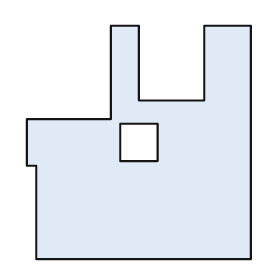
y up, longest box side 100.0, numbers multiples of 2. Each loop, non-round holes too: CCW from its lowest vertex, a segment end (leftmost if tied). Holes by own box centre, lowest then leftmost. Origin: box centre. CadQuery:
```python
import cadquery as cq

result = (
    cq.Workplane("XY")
    .moveTo(-44.0, -50.0)
    .lineTo(48.0, -50.0)
    .lineTo(48.0, 50.0)
    .lineTo(28.0, 50.0)
    .lineTo(28.0, 18.0)
    .lineTo(0.0, 18.0)
    .lineTo(0.0, 50.0)
    .lineTo(-12.0, 50.0)
    .lineTo(-12.0, 10.0)
    .lineTo(-48.0, 10.0)
    .lineTo(-48.0, -10.0)
    .lineTo(-44.0, -10.0)
    .close()
    .moveTo(-8.0, -8.0)
    .lineTo(8.0, -8.0)
    .lineTo(8.0, 8.0)
    .lineTo(-8.0, 8.0)
    .close()
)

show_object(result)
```